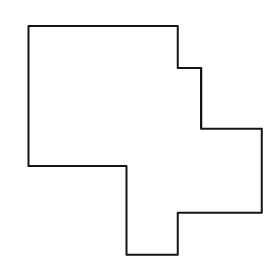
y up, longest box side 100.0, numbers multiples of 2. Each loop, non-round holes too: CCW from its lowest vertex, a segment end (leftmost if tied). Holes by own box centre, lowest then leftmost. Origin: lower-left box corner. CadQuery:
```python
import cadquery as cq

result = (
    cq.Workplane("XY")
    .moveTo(42.0, 0.0)
    .lineTo(64.0, 0.0)
    .lineTo(64.0, 18.0)
    .lineTo(100.0, 18.0)
    .lineTo(100.0, 54.0)
    .lineTo(74.0, 54.0)
    .lineTo(74.0, 80.0)
    .lineTo(64.0, 80.0)
    .lineTo(64.0, 98.0)
    .lineTo(0.0, 98.0)
    .lineTo(0.0, 38.0)
    .lineTo(42.0, 38.0)
    .close()
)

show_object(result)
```